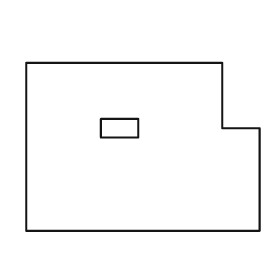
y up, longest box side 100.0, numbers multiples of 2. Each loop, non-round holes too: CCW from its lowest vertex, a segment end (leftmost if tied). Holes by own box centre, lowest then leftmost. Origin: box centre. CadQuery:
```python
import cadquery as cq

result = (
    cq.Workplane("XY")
    .moveTo(-50.0, -36.0)
    .lineTo(50.0, -36.0)
    .lineTo(50.0, 8.0)
    .lineTo(34.0, 8.0)
    .lineTo(34.0, 36.0)
    .lineTo(-50.0, 36.0)
    .close()
    .moveTo(-18.0, 4.0)
    .lineTo(-2.0, 4.0)
    .lineTo(-2.0, 12.0)
    .lineTo(-18.0, 12.0)
    .close()
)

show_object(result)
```